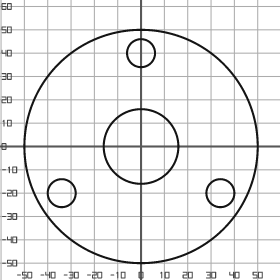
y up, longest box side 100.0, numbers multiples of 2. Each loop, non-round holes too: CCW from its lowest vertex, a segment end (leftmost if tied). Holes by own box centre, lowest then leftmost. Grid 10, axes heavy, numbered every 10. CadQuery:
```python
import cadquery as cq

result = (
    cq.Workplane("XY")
    .moveTo(0.0, 0.0)
    .circle(50.0)
    .moveTo(-34.0, -20.0)
    .circle(6.0)
    .moveTo(34.0, -20.0)
    .circle(6.0)
    .moveTo(0.0, 0.0)
    .circle(16.0)
    .moveTo(0.0, 40.0)
    .circle(6.0)
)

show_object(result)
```